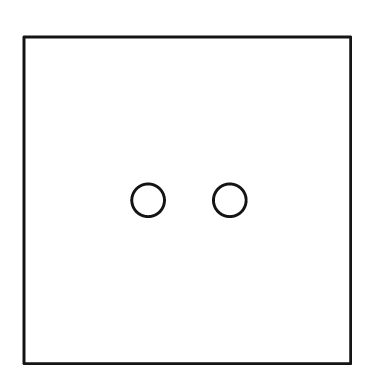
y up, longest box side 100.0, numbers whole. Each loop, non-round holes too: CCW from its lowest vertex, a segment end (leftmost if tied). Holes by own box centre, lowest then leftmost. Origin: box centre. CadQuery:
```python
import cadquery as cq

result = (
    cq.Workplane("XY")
    .moveTo(-50.0, -50.0)
    .lineTo(50.0, -50.0)
    .lineTo(50.0, 50.0)
    .lineTo(-50.0, 50.0)
    .close()
    .moveTo(-12.0, 0.0)
    .circle(5.0)
    .moveTo(13.0, 0.0)
    .circle(5.0)
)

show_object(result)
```